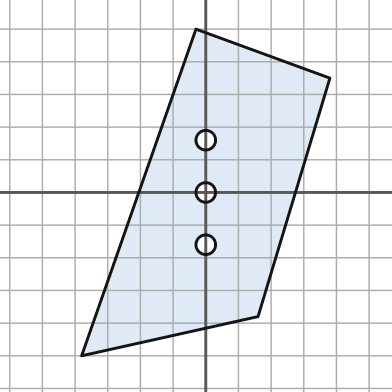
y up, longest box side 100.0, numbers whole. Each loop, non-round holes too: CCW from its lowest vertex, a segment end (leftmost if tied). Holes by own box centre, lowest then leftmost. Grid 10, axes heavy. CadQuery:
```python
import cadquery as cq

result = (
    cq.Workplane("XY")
    .moveTo(-38.0, -50.0)
    .lineTo(16.0, -38.0)
    .lineTo(38.0, 35.0)
    .lineTo(-3.0, 50.0)
    .close()
    .moveTo(0.0, -16.0)
    .circle(3.0)
    .moveTo(0.0, 0.0)
    .circle(3.0)
    .moveTo(0.0, 16.0)
    .circle(3.0)
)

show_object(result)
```